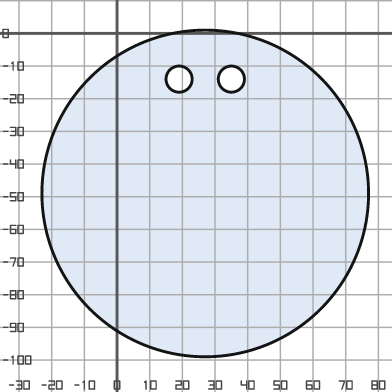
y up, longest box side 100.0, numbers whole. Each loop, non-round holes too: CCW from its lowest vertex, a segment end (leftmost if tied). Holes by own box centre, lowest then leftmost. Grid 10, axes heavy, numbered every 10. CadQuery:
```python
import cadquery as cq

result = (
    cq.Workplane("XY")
    .moveTo(27.0, -49.0)
    .circle(50.0)
    .moveTo(19.0, -14.0)
    .circle(4.0)
    .moveTo(35.0, -14.0)
    .circle(4.0)
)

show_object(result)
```